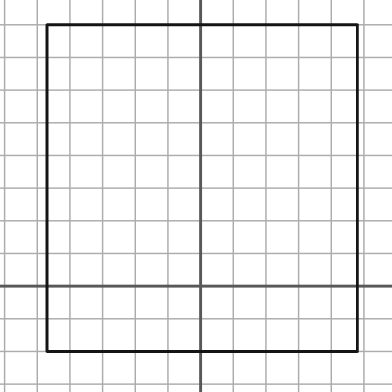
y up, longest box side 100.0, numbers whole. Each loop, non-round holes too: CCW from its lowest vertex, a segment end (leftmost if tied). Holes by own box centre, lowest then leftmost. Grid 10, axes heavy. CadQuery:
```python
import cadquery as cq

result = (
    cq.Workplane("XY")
    .moveTo(-47.0, -20.0)
    .lineTo(48.0, -20.0)
    .lineTo(48.0, 80.0)
    .lineTo(-47.0, 80.0)
    .close()
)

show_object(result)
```